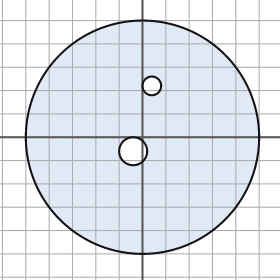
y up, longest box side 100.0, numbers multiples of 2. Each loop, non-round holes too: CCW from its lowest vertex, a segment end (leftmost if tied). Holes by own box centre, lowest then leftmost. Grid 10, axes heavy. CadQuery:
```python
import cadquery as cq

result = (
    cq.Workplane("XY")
    .moveTo(0.0, 0.0)
    .circle(50.0)
    .moveTo(-4.0, -6.0)
    .circle(6.0)
    .moveTo(4.0, 22.0)
    .circle(4.0)
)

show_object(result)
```